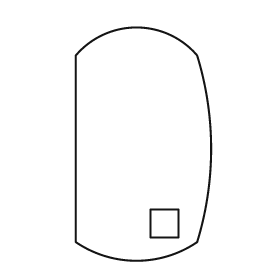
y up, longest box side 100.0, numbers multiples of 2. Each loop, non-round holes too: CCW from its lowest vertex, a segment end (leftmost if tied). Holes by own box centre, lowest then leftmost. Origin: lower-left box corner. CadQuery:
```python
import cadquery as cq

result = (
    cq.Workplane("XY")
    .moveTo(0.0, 8.0)
    .threePointArc((26.0, 0.0), (52.0, 8.0))
    .threePointArc((58.0, 48.0), (52.0, 88.0))
    .threePointArc((26.0, 100.0), (0.0, 88.0))
    .close()
    .moveTo(32.0, 10.0)
    .lineTo(44.0, 10.0)
    .lineTo(44.0, 22.0)
    .lineTo(32.0, 22.0)
    .close()
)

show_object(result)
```